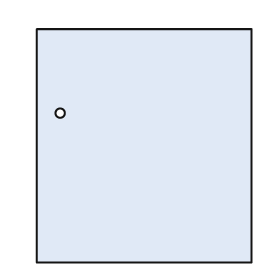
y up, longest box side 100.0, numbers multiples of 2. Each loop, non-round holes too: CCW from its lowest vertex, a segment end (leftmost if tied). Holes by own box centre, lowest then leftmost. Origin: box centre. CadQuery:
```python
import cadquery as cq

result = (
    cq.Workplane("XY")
    .moveTo(-46.0, -50.0)
    .lineTo(46.0, -50.0)
    .lineTo(46.0, 50.0)
    .lineTo(-46.0, 50.0)
    .close()
    .moveTo(-36.0, 14.0)
    .circle(2.0)
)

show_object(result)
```